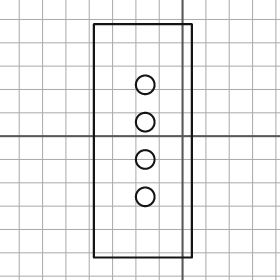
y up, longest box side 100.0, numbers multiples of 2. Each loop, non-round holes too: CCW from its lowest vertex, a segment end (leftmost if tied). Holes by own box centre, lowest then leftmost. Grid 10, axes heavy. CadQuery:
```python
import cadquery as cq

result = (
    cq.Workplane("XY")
    .moveTo(-38.0, -52.0)
    .lineTo(4.0, -52.0)
    .lineTo(4.0, 48.0)
    .lineTo(-38.0, 48.0)
    .close()
    .moveTo(-16.0, -26.0)
    .circle(4.0)
    .moveTo(-16.0, -10.0)
    .circle(4.0)
    .moveTo(-16.0, 6.0)
    .circle(4.0)
    .moveTo(-16.0, 22.0)
    .circle(4.0)
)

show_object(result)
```